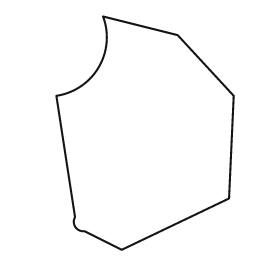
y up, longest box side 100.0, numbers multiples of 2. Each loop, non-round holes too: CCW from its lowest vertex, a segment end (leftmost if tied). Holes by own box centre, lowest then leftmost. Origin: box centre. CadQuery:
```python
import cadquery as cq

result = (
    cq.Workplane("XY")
    .moveTo(-10.0, -50.0)
    .lineTo(36.0, -28.0)
    .lineTo(38.0, 16.0)
    .lineTo(14.0, 42.0)
    .lineTo(-18.0, 50.0)
    .threePointArc((-20.0, 28.0), (-38.0, 16.0))
    .lineTo(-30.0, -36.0)
    .threePointArc((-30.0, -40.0), (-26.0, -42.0))
    .close()
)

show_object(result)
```